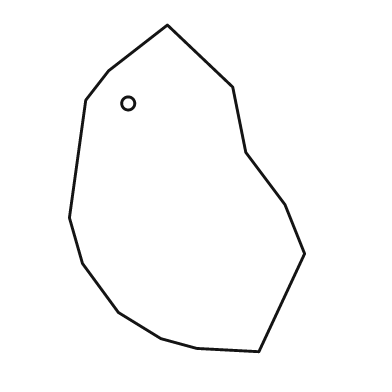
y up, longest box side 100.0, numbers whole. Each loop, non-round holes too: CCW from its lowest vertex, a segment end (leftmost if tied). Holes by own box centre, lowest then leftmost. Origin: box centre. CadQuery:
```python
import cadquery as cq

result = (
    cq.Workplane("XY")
    .moveTo(22.0, -50.0)
    .lineTo(36.0, -20.0)
    .lineTo(30.0, -5.0)
    .lineTo(18.0, 11.0)
    .lineTo(14.0, 31.0)
    .lineTo(-6.0, 50.0)
    .lineTo(-24.0, 36.0)
    .lineTo(-31.0, 27.0)
    .lineTo(-36.0, -9.0)
    .lineTo(-32.0, -23.0)
    .lineTo(-21.0, -38.0)
    .lineTo(-8.0, -46.0)
    .lineTo(3.0, -49.0)
    .close()
    .moveTo(-18.0, 26.0)
    .circle(2.0)
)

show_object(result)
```